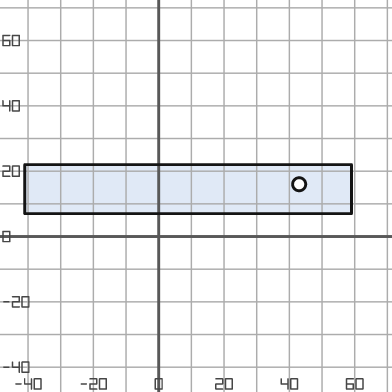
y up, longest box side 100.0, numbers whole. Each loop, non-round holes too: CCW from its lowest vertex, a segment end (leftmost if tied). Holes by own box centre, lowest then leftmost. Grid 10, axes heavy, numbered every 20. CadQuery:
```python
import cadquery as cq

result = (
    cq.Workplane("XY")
    .moveTo(-41.0, 7.0)
    .lineTo(59.0, 7.0)
    .lineTo(59.0, 22.0)
    .lineTo(-41.0, 22.0)
    .close()
    .moveTo(43.0, 16.0)
    .circle(2.0)
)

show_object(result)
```